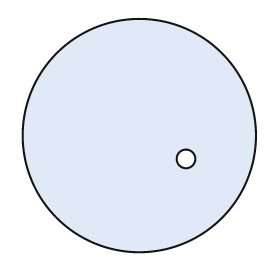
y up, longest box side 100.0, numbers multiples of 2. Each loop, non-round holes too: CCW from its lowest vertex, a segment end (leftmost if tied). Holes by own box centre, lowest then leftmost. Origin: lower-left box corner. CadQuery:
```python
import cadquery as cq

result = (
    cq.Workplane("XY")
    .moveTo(50.0, 50.0)
    .circle(50.0)
    .moveTo(70.0, 40.0)
    .circle(4.0)
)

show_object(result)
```